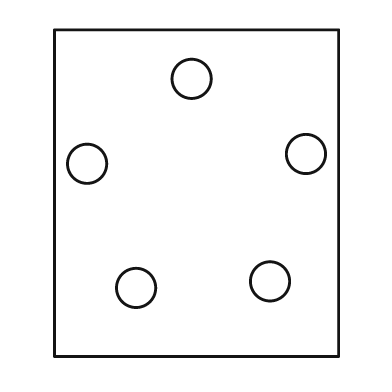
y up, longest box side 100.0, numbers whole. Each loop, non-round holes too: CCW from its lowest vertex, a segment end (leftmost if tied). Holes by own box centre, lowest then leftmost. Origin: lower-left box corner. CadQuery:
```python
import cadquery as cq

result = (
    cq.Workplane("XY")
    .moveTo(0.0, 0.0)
    .lineTo(87.0, 0.0)
    .lineTo(87.0, 100.0)
    .lineTo(0.0, 100.0)
    .close()
    .moveTo(25.0, 21.0)
    .circle(6.0)
    .moveTo(66.0, 23.0)
    .circle(6.0)
    .moveTo(10.0, 59.0)
    .circle(6.0)
    .moveTo(77.0, 62.0)
    .circle(6.0)
    .moveTo(42.0, 85.0)
    .circle(6.0)
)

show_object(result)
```